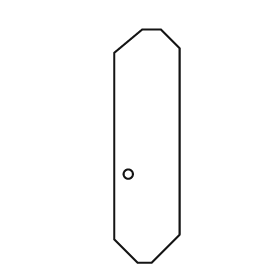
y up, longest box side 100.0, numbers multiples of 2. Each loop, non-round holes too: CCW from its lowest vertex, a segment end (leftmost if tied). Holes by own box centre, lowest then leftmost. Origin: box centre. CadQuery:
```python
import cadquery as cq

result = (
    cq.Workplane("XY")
    .moveTo(-4.0, -50.0)
    .lineTo(2.0, -50.0)
    .lineTo(14.0, -38.0)
    .lineTo(14.0, 42.0)
    .lineTo(6.0, 50.0)
    .lineTo(-2.0, 50.0)
    .lineTo(-14.0, 40.0)
    .lineTo(-14.0, -40.0)
    .close()
    .moveTo(-8.0, -12.0)
    .circle(2.0)
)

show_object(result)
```